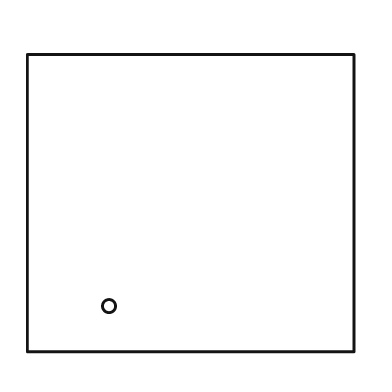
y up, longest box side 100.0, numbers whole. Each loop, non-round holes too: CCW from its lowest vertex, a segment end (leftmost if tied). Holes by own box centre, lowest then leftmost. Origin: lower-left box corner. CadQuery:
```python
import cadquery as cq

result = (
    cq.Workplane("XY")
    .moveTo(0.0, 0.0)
    .lineTo(100.0, 0.0)
    .lineTo(100.0, 91.0)
    .lineTo(0.0, 91.0)
    .close()
    .moveTo(25.0, 14.0)
    .circle(2.0)
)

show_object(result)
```